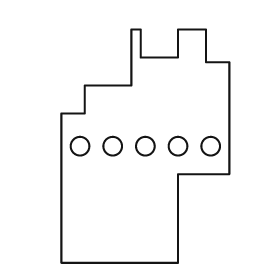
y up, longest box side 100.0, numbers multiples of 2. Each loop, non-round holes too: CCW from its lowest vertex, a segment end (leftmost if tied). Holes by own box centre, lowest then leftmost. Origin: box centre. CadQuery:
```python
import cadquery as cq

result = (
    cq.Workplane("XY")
    .moveTo(-36.0, -50.0)
    .lineTo(14.0, -50.0)
    .lineTo(14.0, -12.0)
    .lineTo(36.0, -12.0)
    .lineTo(36.0, 36.0)
    .lineTo(26.0, 36.0)
    .lineTo(26.0, 50.0)
    .lineTo(14.0, 50.0)
    .lineTo(14.0, 38.0)
    .lineTo(-2.0, 38.0)
    .lineTo(-2.0, 50.0)
    .lineTo(-6.0, 50.0)
    .lineTo(-6.0, 26.0)
    .lineTo(-26.0, 26.0)
    .lineTo(-26.0, 14.0)
    .lineTo(-36.0, 14.0)
    .close()
    .moveTo(-28.0, 0.0)
    .circle(4.0)
    .moveTo(-14.0, 0.0)
    .circle(4.0)
    .moveTo(0.0, 0.0)
    .circle(4.0)
    .moveTo(14.0, 0.0)
    .circle(4.0)
    .moveTo(28.0, 0.0)
    .circle(4.0)
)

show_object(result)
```